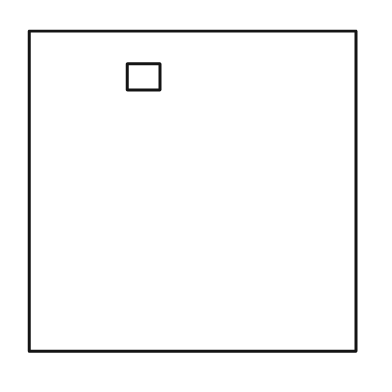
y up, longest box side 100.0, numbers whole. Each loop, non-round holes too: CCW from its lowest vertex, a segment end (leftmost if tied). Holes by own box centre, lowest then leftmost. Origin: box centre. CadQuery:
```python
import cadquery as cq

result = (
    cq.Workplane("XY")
    .moveTo(-50.0, -49.0)
    .lineTo(50.0, -49.0)
    .lineTo(50.0, 49.0)
    .lineTo(-50.0, 49.0)
    .close()
    .moveTo(-20.0, 31.0)
    .lineTo(-10.0, 31.0)
    .lineTo(-10.0, 39.0)
    .lineTo(-20.0, 39.0)
    .close()
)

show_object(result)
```